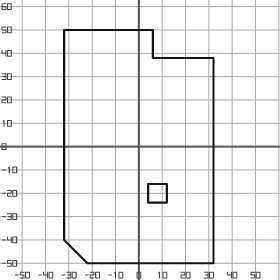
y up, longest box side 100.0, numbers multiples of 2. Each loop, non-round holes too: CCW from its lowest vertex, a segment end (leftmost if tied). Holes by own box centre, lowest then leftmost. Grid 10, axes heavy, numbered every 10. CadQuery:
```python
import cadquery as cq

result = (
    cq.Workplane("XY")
    .moveTo(-22.0, -50.0)
    .lineTo(32.0, -50.0)
    .lineTo(32.0, 38.0)
    .lineTo(6.0, 38.0)
    .lineTo(6.0, 50.0)
    .lineTo(-32.0, 50.0)
    .lineTo(-32.0, -40.0)
    .close()
    .moveTo(4.0, -24.0)
    .lineTo(12.0, -24.0)
    .lineTo(12.0, -16.0)
    .lineTo(4.0, -16.0)
    .close()
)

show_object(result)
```